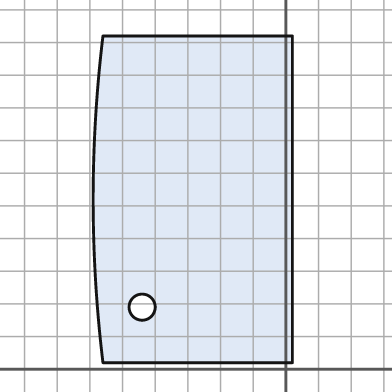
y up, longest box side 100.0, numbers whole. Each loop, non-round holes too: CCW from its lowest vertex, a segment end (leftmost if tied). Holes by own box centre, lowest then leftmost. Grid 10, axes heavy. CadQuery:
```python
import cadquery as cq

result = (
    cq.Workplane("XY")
    .moveTo(-56.0, 2.0)
    .lineTo(2.0, 2.0)
    .lineTo(2.0, 102.0)
    .lineTo(-56.0, 102.0)
    .threePointArc((-59.0, 52.0), (-56.0, 2.0))
    .close()
    .moveTo(-44.0, 19.0)
    .circle(4.0)
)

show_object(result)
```